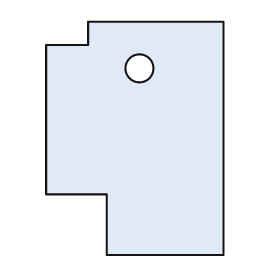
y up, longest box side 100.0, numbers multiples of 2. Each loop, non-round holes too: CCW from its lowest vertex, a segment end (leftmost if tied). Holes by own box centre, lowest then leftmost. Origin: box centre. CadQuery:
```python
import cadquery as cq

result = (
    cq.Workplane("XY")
    .moveTo(-12.0, -50.0)
    .lineTo(38.0, -50.0)
    .lineTo(38.0, 50.0)
    .lineTo(-20.0, 50.0)
    .lineTo(-20.0, 40.0)
    .lineTo(-38.0, 40.0)
    .lineTo(-38.0, -24.0)
    .lineTo(-12.0, -24.0)
    .close()
    .moveTo(2.0, 30.0)
    .circle(6.0)
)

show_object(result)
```